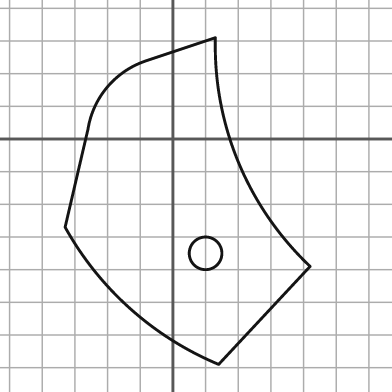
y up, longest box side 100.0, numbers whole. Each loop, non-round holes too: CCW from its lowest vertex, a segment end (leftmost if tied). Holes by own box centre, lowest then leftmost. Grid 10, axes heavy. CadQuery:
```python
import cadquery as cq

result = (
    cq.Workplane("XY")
    .moveTo(14.0, -69.0)
    .lineTo(42.0, -39.0)
    .threePointArc((20.0, -7.0), (13.0, 31.0))
    .lineTo(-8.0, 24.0)
    .threePointArc((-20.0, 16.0), (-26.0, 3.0))
    .lineTo(-33.0, -27.0)
    .threePointArc((-13.0, -52.0), (14.0, -69.0))
    .close()
    .moveTo(10.0, -35.0)
    .circle(5.0)
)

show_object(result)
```